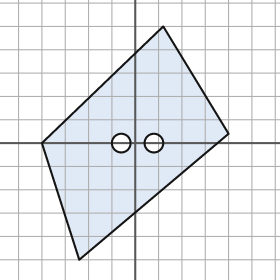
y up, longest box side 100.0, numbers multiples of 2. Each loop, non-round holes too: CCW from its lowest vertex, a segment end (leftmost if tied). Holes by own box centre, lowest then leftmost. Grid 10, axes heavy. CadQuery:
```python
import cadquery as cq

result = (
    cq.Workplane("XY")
    .moveTo(-24.0, -50.0)
    .lineTo(40.0, 4.0)
    .lineTo(12.0, 50.0)
    .lineTo(-40.0, 0.0)
    .close()
    .moveTo(-6.0, 0.0)
    .circle(4.0)
    .moveTo(8.0, 0.0)
    .circle(4.0)
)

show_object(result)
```